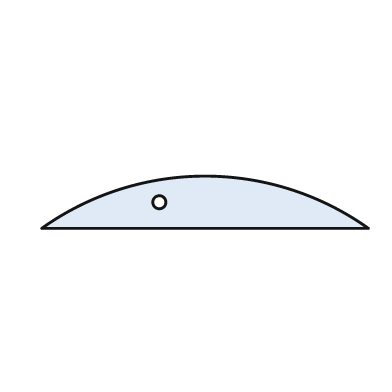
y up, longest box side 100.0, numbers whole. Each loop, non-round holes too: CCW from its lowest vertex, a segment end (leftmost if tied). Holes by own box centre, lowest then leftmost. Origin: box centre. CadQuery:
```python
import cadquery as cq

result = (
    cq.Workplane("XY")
    .moveTo(-50.0, -8.0)
    .lineTo(50.0, -8.0)
    .threePointArc((0.0, 8.0), (-50.0, -8.0))
    .close()
    .moveTo(-14.0, 0.0)
    .circle(2.0)
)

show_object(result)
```